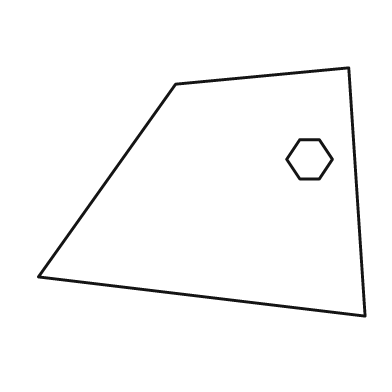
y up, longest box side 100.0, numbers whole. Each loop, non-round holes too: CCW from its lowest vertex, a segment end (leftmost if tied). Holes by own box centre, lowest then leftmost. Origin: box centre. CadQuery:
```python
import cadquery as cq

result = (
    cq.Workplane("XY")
    .moveTo(50.0, -38.0)
    .lineTo(45.0, 38.0)
    .lineTo(-8.0, 33.0)
    .lineTo(-50.0, -26.0)
    .close()
    .moveTo(30.0, 4.0)
    .lineTo(36.0, 4.0)
    .lineTo(40.0, 10.0)
    .lineTo(36.0, 16.0)
    .lineTo(30.0, 16.0)
    .lineTo(26.0, 10.0)
    .close()
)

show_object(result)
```